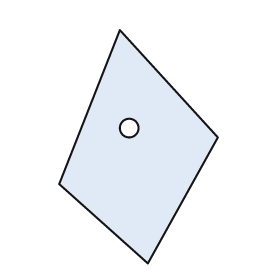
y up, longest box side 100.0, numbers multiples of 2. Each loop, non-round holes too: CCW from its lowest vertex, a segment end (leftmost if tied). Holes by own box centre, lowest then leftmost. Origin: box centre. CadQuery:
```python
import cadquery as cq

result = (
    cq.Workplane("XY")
    .moveTo(4.0, -50.0)
    .lineTo(34.0, 4.0)
    .lineTo(-8.0, 50.0)
    .lineTo(-34.0, -16.0)
    .close()
    .moveTo(-4.0, 8.0)
    .circle(4.0)
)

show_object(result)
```